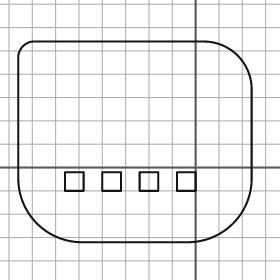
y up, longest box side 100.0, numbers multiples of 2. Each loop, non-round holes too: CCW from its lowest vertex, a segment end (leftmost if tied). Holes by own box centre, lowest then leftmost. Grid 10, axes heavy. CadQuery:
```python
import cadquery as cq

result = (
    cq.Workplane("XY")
    .moveTo(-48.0, -32.0)
    .lineTo(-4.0, -32.0)
    .threePointArc((16.0, -24.0), (24.0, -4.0))
    .lineTo(24.0, 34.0)
    .threePointArc((18.0, 48.0), (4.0, 54.0))
    .lineTo(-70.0, 54.0)
    .threePointArc((-74.0, 52.0), (-76.0, 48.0))
    .lineTo(-76.0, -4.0)
    .threePointArc((-68.0, -24.0), (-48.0, -32.0))
    .close()
    .moveTo(-56.0, -10.0)
    .lineTo(-48.0, -10.0)
    .lineTo(-48.0, -2.0)
    .lineTo(-56.0, -2.0)
    .close()
    .moveTo(-40.0, -10.0)
    .lineTo(-32.0, -10.0)
    .lineTo(-32.0, -2.0)
    .lineTo(-40.0, -2.0)
    .close()
    .moveTo(-24.0, -10.0)
    .lineTo(-16.0, -10.0)
    .lineTo(-16.0, -2.0)
    .lineTo(-24.0, -2.0)
    .close()
    .moveTo(-8.0, -10.0)
    .lineTo(0.0, -10.0)
    .lineTo(0.0, -2.0)
    .lineTo(-8.0, -2.0)
    .close()
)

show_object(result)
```